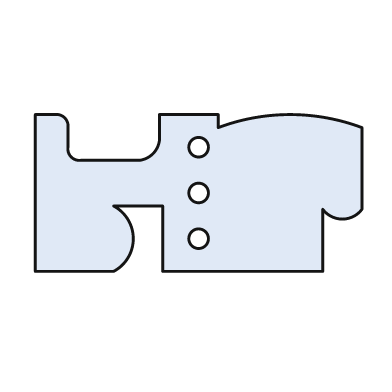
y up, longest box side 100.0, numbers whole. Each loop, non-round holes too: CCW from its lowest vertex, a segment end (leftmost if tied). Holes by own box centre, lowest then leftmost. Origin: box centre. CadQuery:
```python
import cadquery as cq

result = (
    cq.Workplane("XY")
    .moveTo(-50.0, -24.0)
    .lineTo(-26.0, -24.0)
    .threePointArc((-20.0, -14.0), (-26.0, -4.0))
    .lineTo(-11.0, -4.0)
    .lineTo(-11.0, -24.0)
    .lineTo(38.0, -24.0)
    .lineTo(38.0, -5.0)
    .threePointArc((44.0, -8.0), (50.0, -5.0))
    .lineTo(50.0, 20.0)
    .threePointArc((28.0, 24.0), (6.0, 20.0))
    .lineTo(6.0, 24.0)
    .lineTo(-12.0, 24.0)
    .lineTo(-12.0, 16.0)
    .threePointArc((-14.0, 12.0), (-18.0, 10.0))
    .lineTo(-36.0, 10.0)
    .threePointArc((-39.0, 11.0), (-40.0, 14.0))
    .lineTo(-40.0, 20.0)
    .threePointArc((-41.0, 23.0), (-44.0, 24.0))
    .lineTo(-50.0, 24.0)
    .close()
    .moveTo(0.0, -14.0)
    .circle(3.0)
    .moveTo(0.0, 0.0)
    .circle(3.0)
    .moveTo(0.0, 14.0)
    .circle(3.0)
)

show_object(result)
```